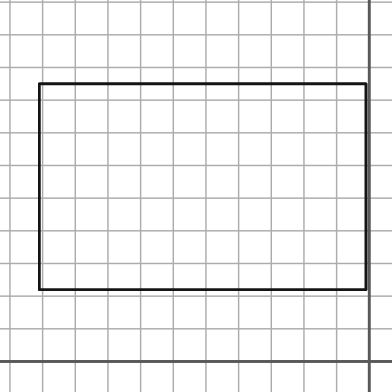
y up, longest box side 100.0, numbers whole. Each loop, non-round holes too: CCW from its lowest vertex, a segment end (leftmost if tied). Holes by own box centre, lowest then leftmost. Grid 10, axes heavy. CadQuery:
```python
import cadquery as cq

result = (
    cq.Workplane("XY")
    .moveTo(-101.0, 22.0)
    .lineTo(-1.0, 22.0)
    .lineTo(-1.0, 85.0)
    .lineTo(-101.0, 85.0)
    .close()
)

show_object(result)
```